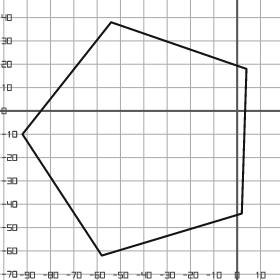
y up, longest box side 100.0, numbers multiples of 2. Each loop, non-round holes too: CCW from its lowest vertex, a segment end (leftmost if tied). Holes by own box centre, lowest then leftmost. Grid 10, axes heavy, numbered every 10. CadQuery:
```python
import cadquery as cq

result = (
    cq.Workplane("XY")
    .moveTo(-58.0, -62.0)
    .lineTo(2.0, -44.0)
    .lineTo(4.0, 18.0)
    .lineTo(-54.0, 38.0)
    .lineTo(-92.0, -10.0)
    .close()
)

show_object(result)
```